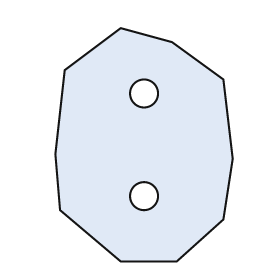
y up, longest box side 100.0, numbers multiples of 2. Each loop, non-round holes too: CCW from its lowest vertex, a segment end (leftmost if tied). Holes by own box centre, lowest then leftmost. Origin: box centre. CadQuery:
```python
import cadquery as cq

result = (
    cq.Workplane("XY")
    .moveTo(-10.0, -50.0)
    .lineTo(14.0, -50.0)
    .lineTo(34.0, -32.0)
    .lineTo(38.0, -6.0)
    .lineTo(34.0, 28.0)
    .lineTo(12.0, 44.0)
    .lineTo(-10.0, 50.0)
    .lineTo(-34.0, 32.0)
    .lineTo(-38.0, -4.0)
    .lineTo(-36.0, -28.0)
    .close()
    .moveTo(0.0, -22.0)
    .circle(6.0)
    .moveTo(0.0, 22.0)
    .circle(6.0)
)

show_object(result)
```